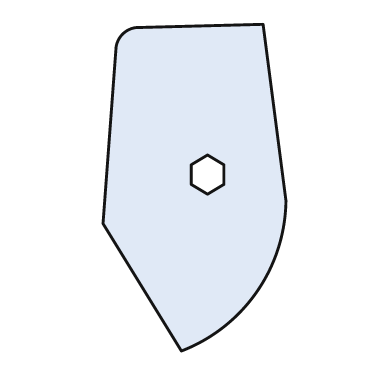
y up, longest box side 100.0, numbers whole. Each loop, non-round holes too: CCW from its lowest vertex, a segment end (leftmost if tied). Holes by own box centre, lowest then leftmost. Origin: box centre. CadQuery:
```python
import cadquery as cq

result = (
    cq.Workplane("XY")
    .moveTo(-4.0, -50.0)
    .threePointArc((19.0, -32.0), (28.0, -4.0))
    .lineTo(21.0, 50.0)
    .lineTo(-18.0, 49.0)
    .threePointArc((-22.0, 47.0), (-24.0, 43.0))
    .lineTo(-28.0, -11.0)
    .close()
    .moveTo(4.0, -2.0)
    .lineTo(9.0, 1.0)
    .lineTo(9.0, 7.0)
    .lineTo(4.0, 10.0)
    .lineTo(-1.0, 7.0)
    .lineTo(-1.0, 1.0)
    .close()
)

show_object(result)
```